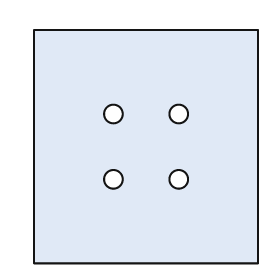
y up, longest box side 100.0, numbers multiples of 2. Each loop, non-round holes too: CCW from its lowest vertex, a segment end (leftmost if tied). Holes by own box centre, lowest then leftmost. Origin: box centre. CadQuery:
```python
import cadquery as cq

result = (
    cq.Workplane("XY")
    .moveTo(-48.0, -50.0)
    .lineTo(48.0, -50.0)
    .lineTo(48.0, 50.0)
    .lineTo(-48.0, 50.0)
    .close()
    .moveTo(-14.0, -14.0)
    .circle(4.0)
    .moveTo(14.0, -14.0)
    .circle(4.0)
    .moveTo(-14.0, 14.0)
    .circle(4.0)
    .moveTo(14.0, 14.0)
    .circle(4.0)
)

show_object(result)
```